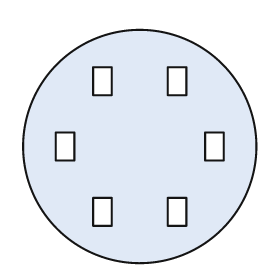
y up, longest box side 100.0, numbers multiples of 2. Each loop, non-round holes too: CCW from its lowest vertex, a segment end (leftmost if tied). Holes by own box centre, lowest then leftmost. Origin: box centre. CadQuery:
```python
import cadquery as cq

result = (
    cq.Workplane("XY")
    .moveTo(0.0, 0.0)
    .circle(50.0)
    .moveTo(-20.0, -34.0)
    .lineTo(-12.0, -34.0)
    .lineTo(-12.0, -22.0)
    .lineTo(-20.0, -22.0)
    .close()
    .moveTo(12.0, -34.0)
    .lineTo(20.0, -34.0)
    .lineTo(20.0, -22.0)
    .lineTo(12.0, -22.0)
    .close()
    .moveTo(-36.0, -6.0)
    .lineTo(-28.0, -6.0)
    .lineTo(-28.0, 6.0)
    .lineTo(-36.0, 6.0)
    .close()
    .moveTo(28.0, -6.0)
    .lineTo(36.0, -6.0)
    .lineTo(36.0, 6.0)
    .lineTo(28.0, 6.0)
    .close()
    .moveTo(-20.0, 22.0)
    .lineTo(-12.0, 22.0)
    .lineTo(-12.0, 34.0)
    .lineTo(-20.0, 34.0)
    .close()
    .moveTo(12.0, 22.0)
    .lineTo(20.0, 22.0)
    .lineTo(20.0, 34.0)
    .lineTo(12.0, 34.0)
    .close()
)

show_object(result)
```